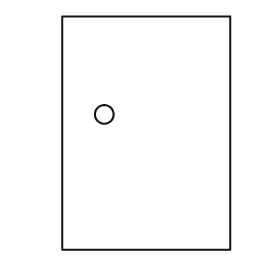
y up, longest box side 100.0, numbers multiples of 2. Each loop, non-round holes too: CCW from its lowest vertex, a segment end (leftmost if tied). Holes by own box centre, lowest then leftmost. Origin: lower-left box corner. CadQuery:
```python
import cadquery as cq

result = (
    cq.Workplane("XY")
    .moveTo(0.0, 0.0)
    .lineTo(72.0, 0.0)
    .lineTo(72.0, 100.0)
    .lineTo(0.0, 100.0)
    .close()
    .moveTo(18.0, 58.0)
    .circle(4.0)
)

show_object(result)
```